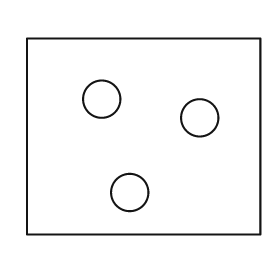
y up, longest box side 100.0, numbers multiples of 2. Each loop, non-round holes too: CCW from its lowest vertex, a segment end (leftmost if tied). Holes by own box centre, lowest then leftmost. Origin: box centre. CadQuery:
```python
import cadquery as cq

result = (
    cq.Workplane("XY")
    .moveTo(-50.0, -42.0)
    .lineTo(50.0, -42.0)
    .lineTo(50.0, 42.0)
    .lineTo(-50.0, 42.0)
    .close()
    .moveTo(-6.0, -24.0)
    .circle(8.0)
    .moveTo(24.0, 8.0)
    .circle(8.0)
    .moveTo(-18.0, 16.0)
    .circle(8.0)
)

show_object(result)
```